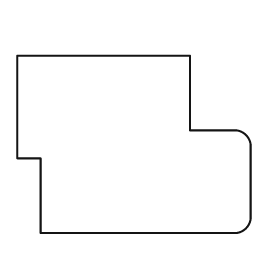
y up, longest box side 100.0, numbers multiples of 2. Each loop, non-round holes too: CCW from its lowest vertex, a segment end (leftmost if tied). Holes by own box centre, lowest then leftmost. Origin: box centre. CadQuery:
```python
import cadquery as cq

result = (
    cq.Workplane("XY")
    .moveTo(-40.0, -38.0)
    .lineTo(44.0, -38.0)
    .threePointArc((48.0, -36.0), (50.0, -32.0))
    .lineTo(50.0, 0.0)
    .threePointArc((48.0, 4.0), (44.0, 6.0))
    .lineTo(24.0, 6.0)
    .lineTo(24.0, 38.0)
    .lineTo(-50.0, 38.0)
    .lineTo(-50.0, -6.0)
    .lineTo(-40.0, -6.0)
    .close()
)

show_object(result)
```